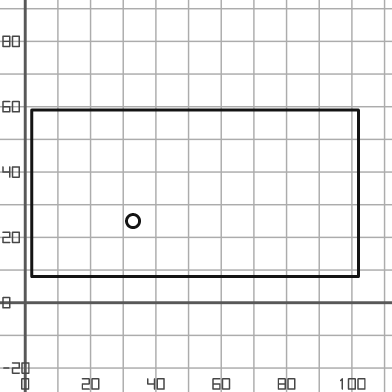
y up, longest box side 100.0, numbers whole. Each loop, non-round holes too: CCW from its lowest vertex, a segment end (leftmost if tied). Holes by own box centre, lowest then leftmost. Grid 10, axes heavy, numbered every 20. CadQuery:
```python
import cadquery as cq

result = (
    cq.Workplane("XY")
    .moveTo(2.0, 8.0)
    .lineTo(102.0, 8.0)
    .lineTo(102.0, 59.0)
    .lineTo(2.0, 59.0)
    .close()
    .moveTo(33.0, 25.0)
    .circle(2.0)
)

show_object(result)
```